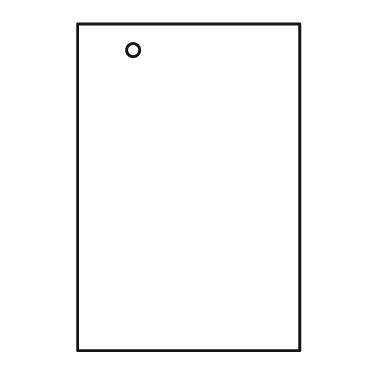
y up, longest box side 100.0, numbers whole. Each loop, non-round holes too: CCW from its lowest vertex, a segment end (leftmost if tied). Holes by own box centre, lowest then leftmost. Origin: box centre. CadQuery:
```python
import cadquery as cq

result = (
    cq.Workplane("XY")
    .moveTo(-34.0, -50.0)
    .lineTo(34.0, -50.0)
    .lineTo(34.0, 50.0)
    .lineTo(-34.0, 50.0)
    .close()
    .moveTo(-17.0, 42.0)
    .circle(2.0)
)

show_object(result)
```